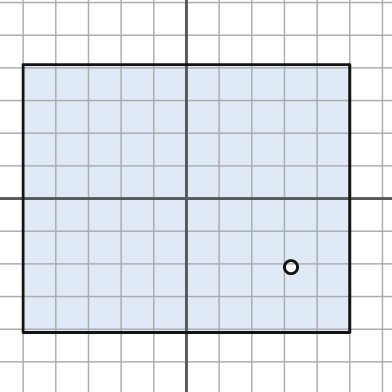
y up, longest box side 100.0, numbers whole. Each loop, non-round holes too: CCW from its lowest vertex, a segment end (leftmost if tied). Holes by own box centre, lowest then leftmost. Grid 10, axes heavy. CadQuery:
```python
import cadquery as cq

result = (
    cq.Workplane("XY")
    .moveTo(-50.0, -41.0)
    .lineTo(50.0, -41.0)
    .lineTo(50.0, 41.0)
    .lineTo(-50.0, 41.0)
    .close()
    .moveTo(32.0, -21.0)
    .circle(2.0)
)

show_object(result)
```